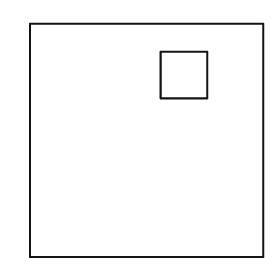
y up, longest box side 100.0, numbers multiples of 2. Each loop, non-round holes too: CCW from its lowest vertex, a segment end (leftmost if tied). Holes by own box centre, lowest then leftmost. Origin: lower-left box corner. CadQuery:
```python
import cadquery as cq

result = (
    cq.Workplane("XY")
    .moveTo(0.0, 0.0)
    .lineTo(100.0, 0.0)
    .lineTo(100.0, 100.0)
    .lineTo(0.0, 100.0)
    .close()
    .moveTo(56.0, 68.0)
    .lineTo(76.0, 68.0)
    .lineTo(76.0, 88.0)
    .lineTo(56.0, 88.0)
    .close()
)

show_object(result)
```